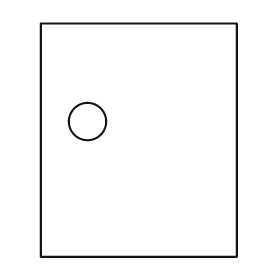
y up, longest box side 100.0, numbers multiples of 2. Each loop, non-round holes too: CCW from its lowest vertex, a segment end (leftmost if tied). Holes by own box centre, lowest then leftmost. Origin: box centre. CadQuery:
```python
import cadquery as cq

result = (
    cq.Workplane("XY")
    .moveTo(-42.0, -50.0)
    .lineTo(42.0, -50.0)
    .lineTo(42.0, 50.0)
    .lineTo(-42.0, 50.0)
    .close()
    .moveTo(-22.0, 8.0)
    .circle(8.0)
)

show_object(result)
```